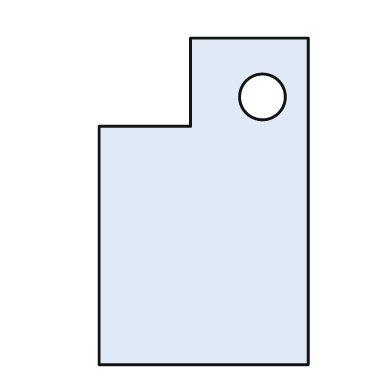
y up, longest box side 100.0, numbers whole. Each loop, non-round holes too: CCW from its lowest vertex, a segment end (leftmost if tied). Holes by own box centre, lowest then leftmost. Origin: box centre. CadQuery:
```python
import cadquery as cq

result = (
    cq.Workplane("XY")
    .moveTo(-32.0, -50.0)
    .lineTo(32.0, -50.0)
    .lineTo(32.0, 50.0)
    .lineTo(-4.0, 50.0)
    .lineTo(-4.0, 23.0)
    .lineTo(-32.0, 23.0)
    .close()
    .moveTo(18.0, 32.0)
    .circle(7.0)
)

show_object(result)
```